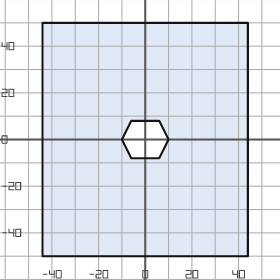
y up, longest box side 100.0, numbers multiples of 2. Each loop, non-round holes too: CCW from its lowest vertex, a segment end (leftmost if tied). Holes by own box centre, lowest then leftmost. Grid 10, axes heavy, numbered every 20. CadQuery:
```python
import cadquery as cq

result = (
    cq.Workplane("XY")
    .moveTo(-44.0, -50.0)
    .lineTo(44.0, -50.0)
    .lineTo(44.0, 50.0)
    .lineTo(-44.0, 50.0)
    .close()
    .moveTo(-6.0, -8.0)
    .lineTo(6.0, -8.0)
    .lineTo(10.0, 0.0)
    .lineTo(6.0, 8.0)
    .lineTo(-6.0, 8.0)
    .lineTo(-10.0, 0.0)
    .close()
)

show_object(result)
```